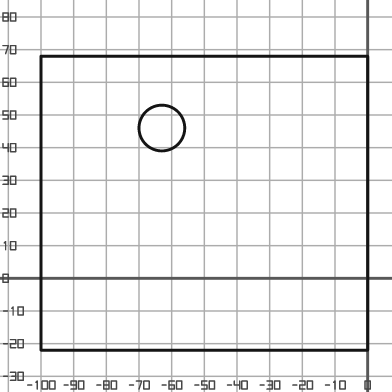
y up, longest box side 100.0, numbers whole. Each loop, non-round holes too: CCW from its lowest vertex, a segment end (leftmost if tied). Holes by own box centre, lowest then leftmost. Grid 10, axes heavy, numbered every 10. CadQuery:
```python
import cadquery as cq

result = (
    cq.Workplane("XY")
    .moveTo(-100.0, -22.0)
    .lineTo(0.0, -22.0)
    .lineTo(0.0, 68.0)
    .lineTo(-100.0, 68.0)
    .close()
    .moveTo(-63.0, 46.0)
    .circle(7.0)
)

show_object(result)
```